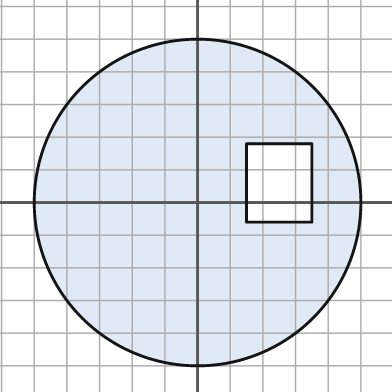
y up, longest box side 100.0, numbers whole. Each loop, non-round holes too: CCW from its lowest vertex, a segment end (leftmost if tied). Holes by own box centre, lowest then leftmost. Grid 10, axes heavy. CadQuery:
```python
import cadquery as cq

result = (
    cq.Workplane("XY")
    .moveTo(0.0, 0.0)
    .circle(50.0)
    .moveTo(15.0, -6.0)
    .lineTo(35.0, -6.0)
    .lineTo(35.0, 18.0)
    .lineTo(15.0, 18.0)
    .close()
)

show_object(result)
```